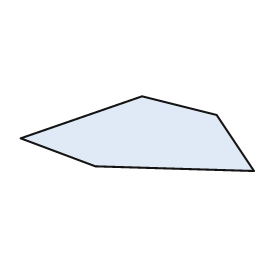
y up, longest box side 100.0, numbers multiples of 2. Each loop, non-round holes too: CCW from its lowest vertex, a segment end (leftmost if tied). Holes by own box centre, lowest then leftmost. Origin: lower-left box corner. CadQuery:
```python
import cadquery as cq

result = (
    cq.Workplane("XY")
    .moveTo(100.0, 0.0)
    .lineTo(84.0, 24.0)
    .lineTo(52.0, 32.0)
    .lineTo(0.0, 14.0)
    .lineTo(32.0, 2.0)
    .close()
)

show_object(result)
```